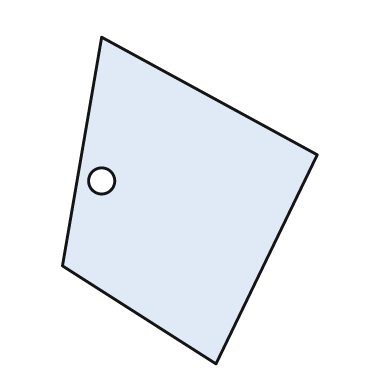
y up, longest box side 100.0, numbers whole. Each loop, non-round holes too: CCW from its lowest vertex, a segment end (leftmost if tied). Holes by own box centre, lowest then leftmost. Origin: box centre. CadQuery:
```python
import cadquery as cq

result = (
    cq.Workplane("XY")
    .moveTo(8.0, -50.0)
    .lineTo(39.0, 14.0)
    .lineTo(-27.0, 50.0)
    .lineTo(-39.0, -20.0)
    .close()
    .moveTo(-27.0, 6.0)
    .circle(4.0)
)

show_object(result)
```